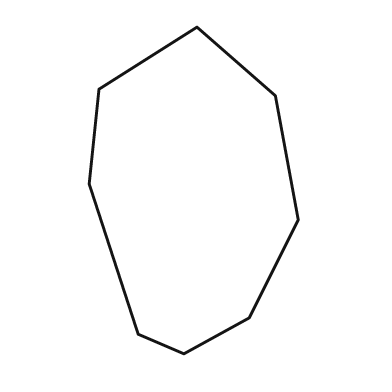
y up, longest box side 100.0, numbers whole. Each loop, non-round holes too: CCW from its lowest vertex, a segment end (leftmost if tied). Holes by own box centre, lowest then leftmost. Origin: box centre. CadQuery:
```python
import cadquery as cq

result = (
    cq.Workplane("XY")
    .moveTo(-3.0, -50.0)
    .lineTo(17.0, -39.0)
    .lineTo(32.0, -9.0)
    .lineTo(25.0, 29.0)
    .lineTo(1.0, 50.0)
    .lineTo(-29.0, 31.0)
    .lineTo(-32.0, 2.0)
    .lineTo(-17.0, -44.0)
    .close()
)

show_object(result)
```